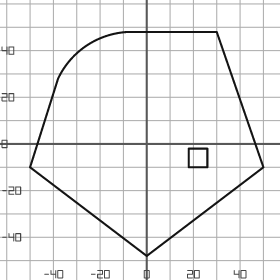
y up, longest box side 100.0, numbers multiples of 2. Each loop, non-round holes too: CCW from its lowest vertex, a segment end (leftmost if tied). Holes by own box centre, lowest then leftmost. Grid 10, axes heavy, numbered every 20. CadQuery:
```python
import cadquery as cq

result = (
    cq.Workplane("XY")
    .moveTo(0.0, -48.0)
    .lineTo(50.0, -10.0)
    .lineTo(30.0, 48.0)
    .lineTo(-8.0, 48.0)
    .threePointArc((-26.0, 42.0), (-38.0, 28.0))
    .lineTo(-50.0, -10.0)
    .close()
    .moveTo(18.0, -10.0)
    .lineTo(26.0, -10.0)
    .lineTo(26.0, -2.0)
    .lineTo(18.0, -2.0)
    .close()
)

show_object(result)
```